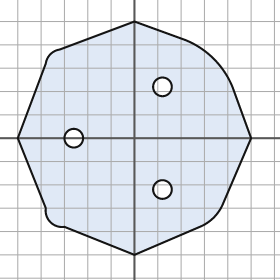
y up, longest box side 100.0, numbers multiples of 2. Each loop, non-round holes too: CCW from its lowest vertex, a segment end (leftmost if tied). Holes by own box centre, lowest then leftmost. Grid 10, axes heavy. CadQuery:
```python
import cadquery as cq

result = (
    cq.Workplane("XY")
    .moveTo(0.0, -50.0)
    .lineTo(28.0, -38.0)
    .threePointArc((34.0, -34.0), (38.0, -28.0))
    .lineTo(50.0, 0.0)
    .lineTo(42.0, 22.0)
    .threePointArc((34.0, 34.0), (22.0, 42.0))
    .lineTo(0.0, 50.0)
    .lineTo(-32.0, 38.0)
    .threePointArc((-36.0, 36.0), (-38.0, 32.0))
    .lineTo(-50.0, 0.0)
    .lineTo(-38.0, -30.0)
    .threePointArc((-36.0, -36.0), (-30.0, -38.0))
    .close()
    .moveTo(12.0, -22.0)
    .circle(4.0)
    .moveTo(-26.0, 0.0)
    .circle(4.0)
    .moveTo(12.0, 22.0)
    .circle(4.0)
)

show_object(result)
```